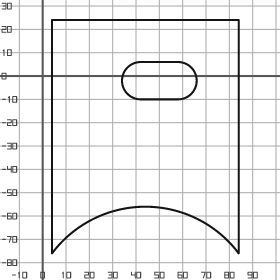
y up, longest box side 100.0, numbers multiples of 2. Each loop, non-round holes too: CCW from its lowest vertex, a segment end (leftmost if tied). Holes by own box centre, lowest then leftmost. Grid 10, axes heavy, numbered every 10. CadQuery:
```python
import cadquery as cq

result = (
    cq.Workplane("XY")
    .moveTo(4.0, -76.0)
    .threePointArc((44.0, -56.0), (84.0, -76.0))
    .lineTo(84.0, 24.0)
    .lineTo(4.0, 24.0)
    .close()
    .moveTo(42.0, -10.0)
    .lineTo(58.0, -10.0)
    .threePointArc((66.0, -2.0), (58.0, 6.0))
    .lineTo(42.0, 6.0)
    .threePointArc((34.0, -2.0), (42.0, -10.0))
    .close()
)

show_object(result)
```